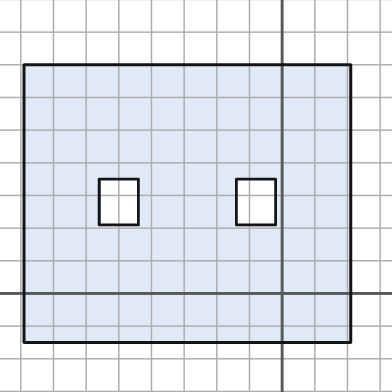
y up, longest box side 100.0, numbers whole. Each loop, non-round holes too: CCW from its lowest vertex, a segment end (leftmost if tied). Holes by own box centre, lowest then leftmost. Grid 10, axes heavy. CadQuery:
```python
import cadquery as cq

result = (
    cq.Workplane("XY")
    .moveTo(-79.0, -15.0)
    .lineTo(21.0, -15.0)
    .lineTo(21.0, 70.0)
    .lineTo(-79.0, 70.0)
    .close()
    .moveTo(-56.0, 21.0)
    .lineTo(-44.0, 21.0)
    .lineTo(-44.0, 35.0)
    .lineTo(-56.0, 35.0)
    .close()
    .moveTo(-14.0, 21.0)
    .lineTo(-2.0, 21.0)
    .lineTo(-2.0, 35.0)
    .lineTo(-14.0, 35.0)
    .close()
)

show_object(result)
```